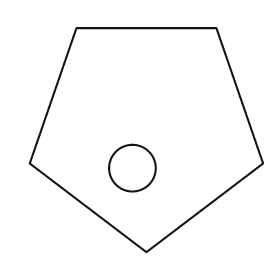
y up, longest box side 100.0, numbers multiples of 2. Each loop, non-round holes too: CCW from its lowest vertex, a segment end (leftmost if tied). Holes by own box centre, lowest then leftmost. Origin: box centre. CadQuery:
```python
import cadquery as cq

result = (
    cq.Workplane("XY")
    .moveTo(0.0, -48.0)
    .lineTo(50.0, -10.0)
    .lineTo(30.0, 48.0)
    .lineTo(-30.0, 48.0)
    .lineTo(-50.0, -10.0)
    .close()
    .moveTo(-6.0, -12.0)
    .circle(10.0)
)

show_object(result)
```